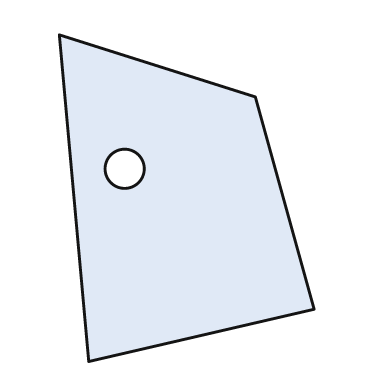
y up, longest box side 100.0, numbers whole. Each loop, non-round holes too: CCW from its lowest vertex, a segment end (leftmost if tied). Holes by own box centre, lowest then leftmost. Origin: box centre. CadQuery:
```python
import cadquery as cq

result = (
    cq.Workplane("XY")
    .moveTo(-30.0, -50.0)
    .lineTo(39.0, -34.0)
    .lineTo(21.0, 31.0)
    .lineTo(-39.0, 50.0)
    .close()
    .moveTo(-19.0, 9.0)
    .circle(6.0)
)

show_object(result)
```